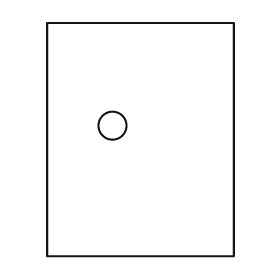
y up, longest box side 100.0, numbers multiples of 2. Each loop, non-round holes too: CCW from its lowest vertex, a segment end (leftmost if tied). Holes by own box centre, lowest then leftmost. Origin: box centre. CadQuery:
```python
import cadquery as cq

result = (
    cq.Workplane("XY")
    .moveTo(-40.0, -50.0)
    .lineTo(40.0, -50.0)
    .lineTo(40.0, 50.0)
    .lineTo(-40.0, 50.0)
    .close()
    .moveTo(-12.0, 6.0)
    .circle(6.0)
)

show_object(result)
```